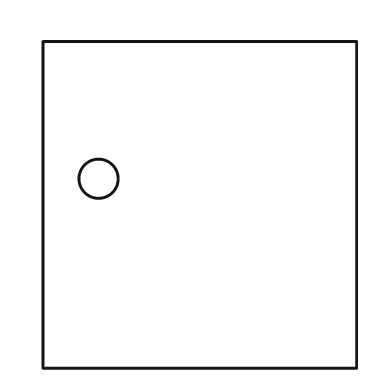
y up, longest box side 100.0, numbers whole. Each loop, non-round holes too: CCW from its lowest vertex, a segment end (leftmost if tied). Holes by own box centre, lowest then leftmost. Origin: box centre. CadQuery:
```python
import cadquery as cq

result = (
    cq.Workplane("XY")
    .moveTo(-48.0, -50.0)
    .lineTo(48.0, -50.0)
    .lineTo(48.0, 50.0)
    .lineTo(-48.0, 50.0)
    .close()
    .moveTo(-31.0, 8.0)
    .circle(6.0)
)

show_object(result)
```